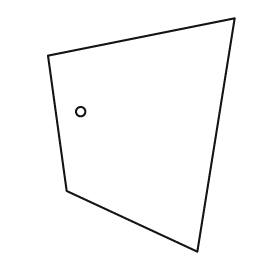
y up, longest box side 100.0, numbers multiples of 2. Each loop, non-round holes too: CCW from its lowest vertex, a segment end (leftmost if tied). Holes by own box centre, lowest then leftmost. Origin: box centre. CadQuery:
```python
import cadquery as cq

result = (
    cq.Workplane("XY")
    .moveTo(24.0, -50.0)
    .lineTo(40.0, 50.0)
    .lineTo(-40.0, 34.0)
    .lineTo(-32.0, -24.0)
    .close()
    .moveTo(-26.0, 10.0)
    .circle(2.0)
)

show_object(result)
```